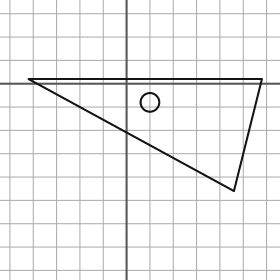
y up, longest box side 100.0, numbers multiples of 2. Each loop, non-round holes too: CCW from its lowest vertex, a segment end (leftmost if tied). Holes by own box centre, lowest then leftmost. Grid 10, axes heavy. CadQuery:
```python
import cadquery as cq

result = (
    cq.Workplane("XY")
    .moveTo(46.0, -46.0)
    .lineTo(58.0, 2.0)
    .lineTo(-42.0, 2.0)
    .close()
    .moveTo(10.0, -8.0)
    .circle(4.0)
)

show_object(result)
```